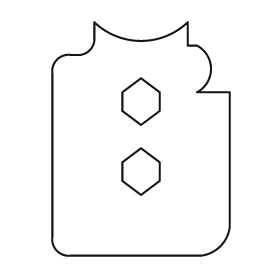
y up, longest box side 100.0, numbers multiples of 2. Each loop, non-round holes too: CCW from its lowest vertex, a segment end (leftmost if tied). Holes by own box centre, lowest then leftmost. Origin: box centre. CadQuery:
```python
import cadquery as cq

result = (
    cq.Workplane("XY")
    .moveTo(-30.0, -50.0)
    .lineTo(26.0, -50.0)
    .threePointArc((34.0, -46.0), (38.0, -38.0))
    .lineTo(38.0, 20.0)
    .lineTo(24.0, 20.0)
    .threePointArc((30.0, 30.0), (24.0, 40.0))
    .lineTo(20.0, 40.0)
    .lineTo(20.0, 50.0)
    .threePointArc((0.0, 42.0), (-20.0, 50.0))
    .lineTo(-20.0, 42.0)
    .threePointArc((-22.0, 38.0), (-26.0, 36.0))
    .lineTo(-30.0, 36.0)
    .threePointArc((-36.0, 34.0), (-38.0, 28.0))
    .lineTo(-38.0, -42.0)
    .threePointArc((-36.0, -48.0), (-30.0, -50.0))
    .close()
    .moveTo(0.0, -24.0)
    .lineTo(8.0, -18.0)
    .lineTo(8.0, -10.0)
    .lineTo(0.0, -4.0)
    .lineTo(-8.0, -10.0)
    .lineTo(-8.0, -18.0)
    .close()
    .moveTo(0.0, 6.0)
    .lineTo(8.0, 12.0)
    .lineTo(8.0, 20.0)
    .lineTo(0.0, 26.0)
    .lineTo(-8.0, 20.0)
    .lineTo(-8.0, 12.0)
    .close()
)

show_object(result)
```